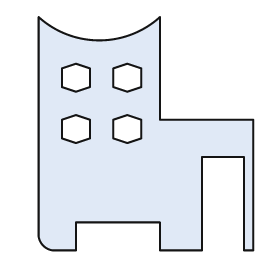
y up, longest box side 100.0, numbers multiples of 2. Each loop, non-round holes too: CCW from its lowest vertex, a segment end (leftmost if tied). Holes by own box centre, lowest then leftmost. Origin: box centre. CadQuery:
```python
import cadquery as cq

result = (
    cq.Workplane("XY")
    .moveTo(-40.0, -50.0)
    .lineTo(-30.0, -50.0)
    .lineTo(-30.0, -38.0)
    .lineTo(6.0, -38.0)
    .lineTo(6.0, -50.0)
    .lineTo(24.0, -50.0)
    .lineTo(24.0, -10.0)
    .lineTo(42.0, -10.0)
    .lineTo(42.0, -50.0)
    .lineTo(46.0, -50.0)
    .lineTo(46.0, 6.0)
    .lineTo(6.0, 6.0)
    .lineTo(6.0, 50.0)
    .threePointArc((-20.0, 40.0), (-46.0, 50.0))
    .lineTo(-46.0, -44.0)
    .threePointArc((-44.0, -48.0), (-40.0, -50.0))
    .close()
    .moveTo(-30.0, -4.0)
    .lineTo(-24.0, -2.0)
    .lineTo(-24.0, 6.0)
    .lineTo(-30.0, 8.0)
    .lineTo(-36.0, 6.0)
    .lineTo(-36.0, -2.0)
    .close()
    .moveTo(-8.0, -4.0)
    .lineTo(-2.0, -2.0)
    .lineTo(-2.0, 6.0)
    .lineTo(-8.0, 8.0)
    .lineTo(-14.0, 6.0)
    .lineTo(-14.0, -2.0)
    .close()
    .moveTo(-30.0, 18.0)
    .lineTo(-24.0, 20.0)
    .lineTo(-24.0, 28.0)
    .lineTo(-30.0, 30.0)
    .lineTo(-36.0, 28.0)
    .lineTo(-36.0, 20.0)
    .close()
    .moveTo(-8.0, 18.0)
    .lineTo(-2.0, 20.0)
    .lineTo(-2.0, 28.0)
    .lineTo(-8.0, 30.0)
    .lineTo(-14.0, 28.0)
    .lineTo(-14.0, 20.0)
    .close()
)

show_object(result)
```